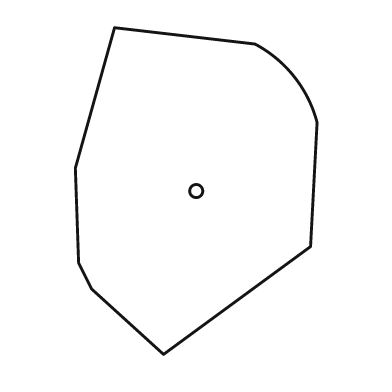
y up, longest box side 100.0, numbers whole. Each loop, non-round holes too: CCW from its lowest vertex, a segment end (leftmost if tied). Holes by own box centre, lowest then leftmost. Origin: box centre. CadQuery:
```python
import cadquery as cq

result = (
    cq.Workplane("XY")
    .moveTo(-10.0, -50.0)
    .lineTo(35.0, -17.0)
    .lineTo(37.0, 21.0)
    .threePointArc((30.0, 35.0), (18.0, 45.0))
    .lineTo(-25.0, 50.0)
    .lineTo(-37.0, 7.0)
    .lineTo(-36.0, -22.0)
    .lineTo(-32.0, -30.0)
    .close()
    .moveTo(0.0, 0.0)
    .circle(2.0)
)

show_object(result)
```